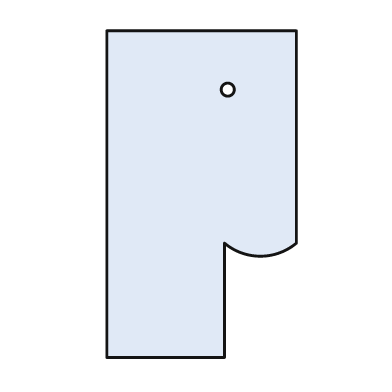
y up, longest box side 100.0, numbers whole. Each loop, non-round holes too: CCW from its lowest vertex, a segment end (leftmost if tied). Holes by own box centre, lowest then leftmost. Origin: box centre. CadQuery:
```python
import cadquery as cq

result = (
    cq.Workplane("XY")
    .moveTo(-29.0, -50.0)
    .lineTo(7.0, -50.0)
    .lineTo(7.0, -15.0)
    .threePointArc((18.0, -19.0), (29.0, -15.0))
    .lineTo(29.0, 50.0)
    .lineTo(-29.0, 50.0)
    .close()
    .moveTo(8.0, 32.0)
    .circle(2.0)
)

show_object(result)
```